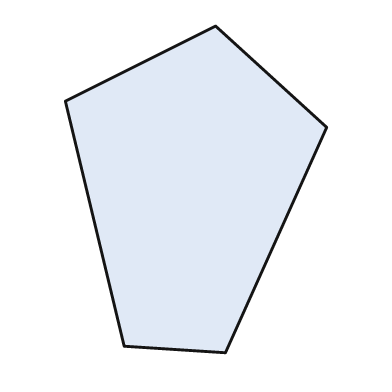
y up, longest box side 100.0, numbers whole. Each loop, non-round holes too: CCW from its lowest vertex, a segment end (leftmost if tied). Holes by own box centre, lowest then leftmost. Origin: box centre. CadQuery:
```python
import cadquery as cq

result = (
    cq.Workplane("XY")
    .moveTo(9.0, -50.0)
    .lineTo(40.0, 19.0)
    .lineTo(6.0, 50.0)
    .lineTo(-40.0, 27.0)
    .lineTo(-22.0, -48.0)
    .close()
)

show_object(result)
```